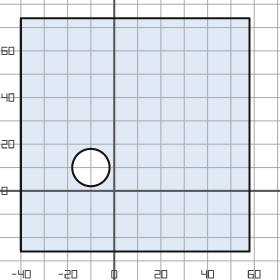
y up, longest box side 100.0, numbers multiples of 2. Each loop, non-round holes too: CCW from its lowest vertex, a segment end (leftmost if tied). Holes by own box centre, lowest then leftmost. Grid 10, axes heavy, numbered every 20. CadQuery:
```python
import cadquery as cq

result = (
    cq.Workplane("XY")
    .moveTo(-40.0, -26.0)
    .lineTo(58.0, -26.0)
    .lineTo(58.0, 74.0)
    .lineTo(-40.0, 74.0)
    .close()
    .moveTo(-10.0, 10.0)
    .circle(8.0)
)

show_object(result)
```